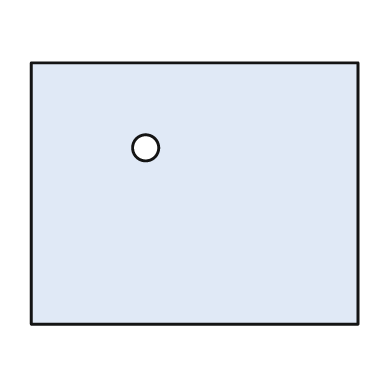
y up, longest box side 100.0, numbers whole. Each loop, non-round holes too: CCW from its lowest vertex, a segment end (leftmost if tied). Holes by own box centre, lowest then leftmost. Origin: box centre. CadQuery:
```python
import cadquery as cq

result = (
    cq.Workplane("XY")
    .moveTo(-50.0, -40.0)
    .lineTo(50.0, -40.0)
    .lineTo(50.0, 40.0)
    .lineTo(-50.0, 40.0)
    .close()
    .moveTo(-15.0, 14.0)
    .circle(4.0)
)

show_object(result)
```